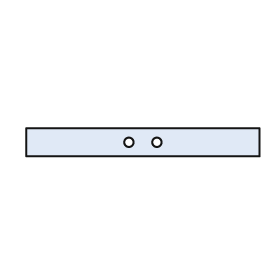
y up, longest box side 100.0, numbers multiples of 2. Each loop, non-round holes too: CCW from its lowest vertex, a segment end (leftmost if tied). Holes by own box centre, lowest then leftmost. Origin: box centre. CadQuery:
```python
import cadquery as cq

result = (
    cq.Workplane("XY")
    .moveTo(-50.0, -6.0)
    .lineTo(50.0, -6.0)
    .lineTo(50.0, 6.0)
    .lineTo(-50.0, 6.0)
    .close()
    .moveTo(-6.0, 0.0)
    .circle(2.0)
    .moveTo(6.0, 0.0)
    .circle(2.0)
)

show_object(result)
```